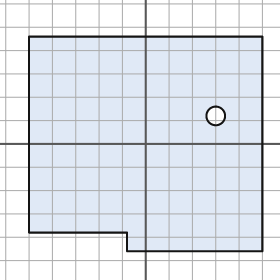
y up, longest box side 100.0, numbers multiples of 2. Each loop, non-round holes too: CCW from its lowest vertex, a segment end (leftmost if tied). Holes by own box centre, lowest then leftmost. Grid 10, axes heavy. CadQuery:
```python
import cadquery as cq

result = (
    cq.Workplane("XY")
    .moveTo(-8.0, -46.0)
    .lineTo(50.0, -46.0)
    .lineTo(50.0, 46.0)
    .lineTo(-50.0, 46.0)
    .lineTo(-50.0, -38.0)
    .lineTo(-8.0, -38.0)
    .close()
    .moveTo(30.0, 12.0)
    .circle(4.0)
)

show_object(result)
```